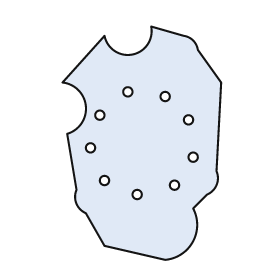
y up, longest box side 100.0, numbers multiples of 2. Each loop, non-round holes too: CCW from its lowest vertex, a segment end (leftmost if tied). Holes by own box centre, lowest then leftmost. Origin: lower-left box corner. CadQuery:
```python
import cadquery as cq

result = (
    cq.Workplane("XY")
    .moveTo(44.0, 0.0)
    .threePointArc((56.0, 8.0), (56.0, 22.0))
    .lineTo(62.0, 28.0)
    .threePointArc((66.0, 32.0), (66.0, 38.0))
    .lineTo(68.0, 76.0)
    .lineTo(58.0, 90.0)
    .threePointArc((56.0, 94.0), (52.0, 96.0))
    .lineTo(38.0, 100.0)
    .threePointArc((30.0, 88.0), (18.0, 96.0))
    .lineTo(0.0, 76.0)
    .threePointArc((10.0, 66.0), (2.0, 54.0))
    .lineTo(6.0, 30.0)
    .threePointArc((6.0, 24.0), (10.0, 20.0))
    .lineTo(18.0, 6.0)
    .close()
    .moveTo(32.0, 28.0)
    .circle(2.0)
    .moveTo(48.0, 32.0)
    .circle(2.0)
    .moveTo(18.0, 34.0)
    .circle(2.0)
    .moveTo(56.0, 44.0)
    .circle(2.0)
    .moveTo(12.0, 48.0)
    .circle(2.0)
    .moveTo(54.0, 60.0)
    .circle(2.0)
    .moveTo(16.0, 62.0)
    .circle(2.0)
    .moveTo(44.0, 70.0)
    .circle(2.0)
    .moveTo(28.0, 72.0)
    .circle(2.0)
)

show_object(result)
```